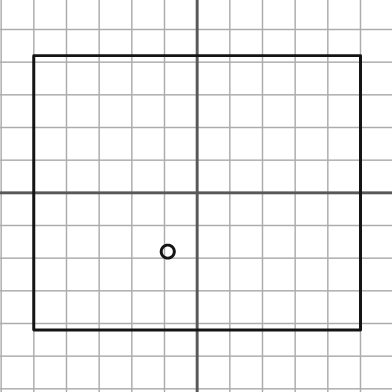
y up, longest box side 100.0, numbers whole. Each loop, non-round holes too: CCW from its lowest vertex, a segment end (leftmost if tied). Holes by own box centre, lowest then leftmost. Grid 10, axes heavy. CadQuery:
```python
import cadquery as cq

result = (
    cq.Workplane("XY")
    .moveTo(-50.0, -42.0)
    .lineTo(50.0, -42.0)
    .lineTo(50.0, 42.0)
    .lineTo(-50.0, 42.0)
    .close()
    .moveTo(-9.0, -18.0)
    .circle(2.0)
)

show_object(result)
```